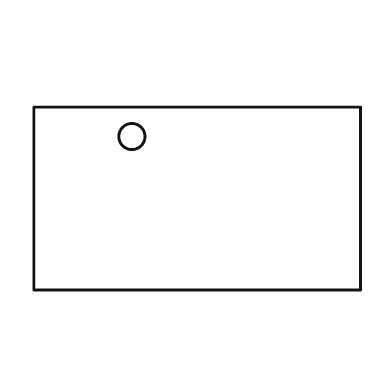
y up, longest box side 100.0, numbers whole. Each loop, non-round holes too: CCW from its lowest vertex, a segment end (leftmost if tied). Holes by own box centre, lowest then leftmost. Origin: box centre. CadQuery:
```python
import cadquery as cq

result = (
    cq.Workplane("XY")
    .moveTo(-50.0, -28.0)
    .lineTo(50.0, -28.0)
    .lineTo(50.0, 28.0)
    .lineTo(-50.0, 28.0)
    .close()
    .moveTo(-20.0, 19.0)
    .circle(4.0)
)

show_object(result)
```